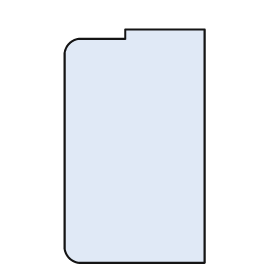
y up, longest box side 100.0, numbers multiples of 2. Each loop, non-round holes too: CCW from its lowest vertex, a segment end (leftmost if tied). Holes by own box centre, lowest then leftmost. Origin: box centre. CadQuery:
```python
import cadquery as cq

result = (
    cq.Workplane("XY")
    .moveTo(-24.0, -50.0)
    .lineTo(30.0, -50.0)
    .lineTo(30.0, 50.0)
    .lineTo(-4.0, 50.0)
    .lineTo(-4.0, 46.0)
    .lineTo(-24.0, 46.0)
    .threePointArc((-28.0, 44.0), (-30.0, 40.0))
    .lineTo(-30.0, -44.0)
    .threePointArc((-28.0, -48.0), (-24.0, -50.0))
    .close()
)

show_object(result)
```